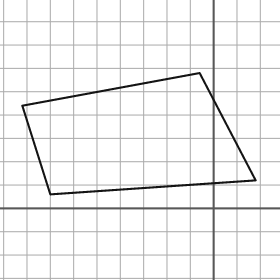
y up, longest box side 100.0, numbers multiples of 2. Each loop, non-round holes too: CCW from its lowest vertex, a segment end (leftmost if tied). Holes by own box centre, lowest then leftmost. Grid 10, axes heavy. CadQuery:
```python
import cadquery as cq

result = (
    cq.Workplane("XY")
    .moveTo(-70.0, 6.0)
    .lineTo(18.0, 12.0)
    .lineTo(-6.0, 58.0)
    .lineTo(-82.0, 44.0)
    .close()
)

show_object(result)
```